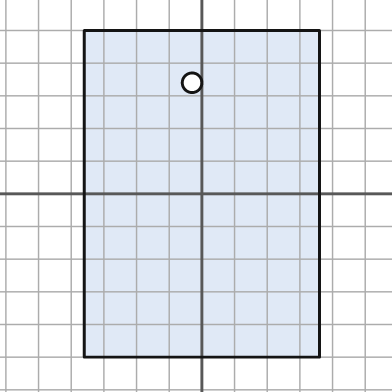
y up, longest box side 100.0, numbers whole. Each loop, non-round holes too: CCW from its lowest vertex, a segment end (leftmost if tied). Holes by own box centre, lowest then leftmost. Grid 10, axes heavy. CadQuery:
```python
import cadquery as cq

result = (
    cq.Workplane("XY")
    .moveTo(-36.0, -50.0)
    .lineTo(36.0, -50.0)
    .lineTo(36.0, 50.0)
    .lineTo(-36.0, 50.0)
    .close()
    .moveTo(-3.0, 34.0)
    .circle(3.0)
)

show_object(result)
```